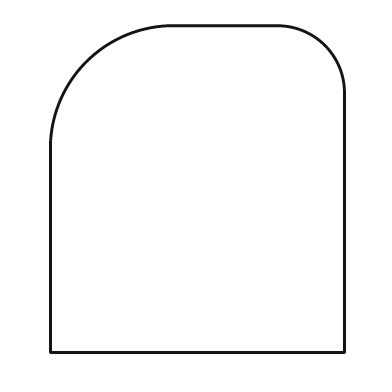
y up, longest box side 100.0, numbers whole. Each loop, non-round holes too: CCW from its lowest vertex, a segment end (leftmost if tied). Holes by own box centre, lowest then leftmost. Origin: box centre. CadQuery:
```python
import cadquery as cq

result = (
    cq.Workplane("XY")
    .moveTo(-45.0, -50.0)
    .lineTo(45.0, -50.0)
    .lineTo(45.0, 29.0)
    .threePointArc((39.0, 44.0), (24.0, 50.0))
    .lineTo(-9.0, 50.0)
    .threePointArc((-34.0, 39.0), (-45.0, 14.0))
    .close()
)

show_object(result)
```